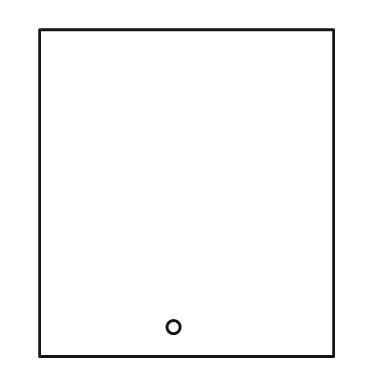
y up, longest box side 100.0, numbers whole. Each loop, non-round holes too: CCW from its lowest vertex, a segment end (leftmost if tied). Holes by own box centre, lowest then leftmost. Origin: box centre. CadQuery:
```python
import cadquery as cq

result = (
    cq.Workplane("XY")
    .moveTo(-45.0, -50.0)
    .lineTo(45.0, -50.0)
    .lineTo(45.0, 50.0)
    .lineTo(-45.0, 50.0)
    .close()
    .moveTo(-4.0, -41.0)
    .circle(2.0)
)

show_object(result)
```